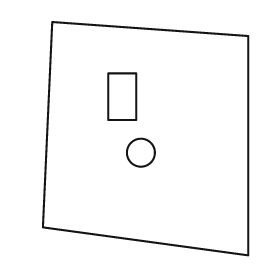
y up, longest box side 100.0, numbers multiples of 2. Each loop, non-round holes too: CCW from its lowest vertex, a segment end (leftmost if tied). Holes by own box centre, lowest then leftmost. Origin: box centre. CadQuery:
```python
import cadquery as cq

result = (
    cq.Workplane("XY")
    .moveTo(44.0, -50.0)
    .lineTo(44.0, 44.0)
    .lineTo(-40.0, 50.0)
    .lineTo(-44.0, -38.0)
    .close()
    .moveTo(-2.0, -6.0)
    .circle(6.0)
    .moveTo(-16.0, 8.0)
    .lineTo(-4.0, 8.0)
    .lineTo(-4.0, 28.0)
    .lineTo(-16.0, 28.0)
    .close()
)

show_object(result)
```